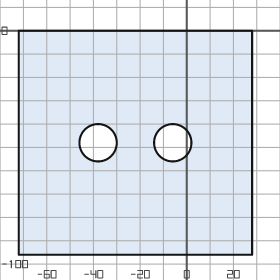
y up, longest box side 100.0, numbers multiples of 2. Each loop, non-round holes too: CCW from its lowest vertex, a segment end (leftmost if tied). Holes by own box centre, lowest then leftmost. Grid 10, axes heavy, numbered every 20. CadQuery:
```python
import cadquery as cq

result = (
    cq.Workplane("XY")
    .moveTo(-72.0, -96.0)
    .lineTo(28.0, -96.0)
    .lineTo(28.0, 0.0)
    .lineTo(-72.0, 0.0)
    .close()
    .moveTo(-38.0, -48.0)
    .circle(8.0)
    .moveTo(-6.0, -48.0)
    .circle(8.0)
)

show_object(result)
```